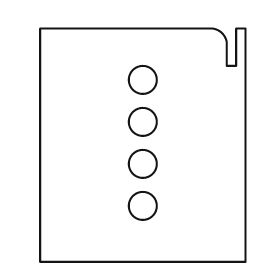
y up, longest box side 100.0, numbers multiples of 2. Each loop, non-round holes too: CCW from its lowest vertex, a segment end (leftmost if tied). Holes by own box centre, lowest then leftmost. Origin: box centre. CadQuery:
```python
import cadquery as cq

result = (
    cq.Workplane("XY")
    .moveTo(-44.0, -50.0)
    .lineTo(44.0, -50.0)
    .lineTo(44.0, 50.0)
    .lineTo(40.0, 50.0)
    .lineTo(40.0, 34.0)
    .lineTo(36.0, 34.0)
    .lineTo(36.0, 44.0)
    .threePointArc((34.0, 48.0), (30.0, 50.0))
    .lineTo(-44.0, 50.0)
    .close()
    .moveTo(0.0, -26.0)
    .circle(6.0)
    .moveTo(0.0, -8.0)
    .circle(6.0)
    .moveTo(0.0, 10.0)
    .circle(6.0)
    .moveTo(0.0, 28.0)
    .circle(6.0)
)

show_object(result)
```